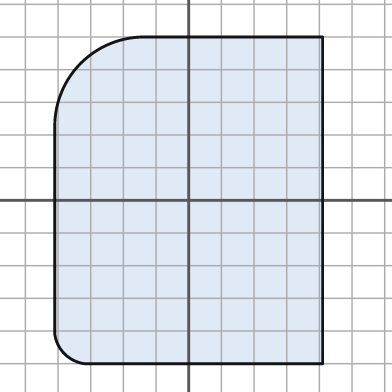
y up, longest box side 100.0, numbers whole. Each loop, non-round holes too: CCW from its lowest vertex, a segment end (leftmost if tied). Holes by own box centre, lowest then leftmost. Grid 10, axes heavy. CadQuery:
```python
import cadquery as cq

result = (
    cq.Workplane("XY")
    .moveTo(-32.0, -50.0)
    .lineTo(41.0, -50.0)
    .lineTo(41.0, 50.0)
    .lineTo(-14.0, 50.0)
    .threePointArc((-33.0, 42.0), (-41.0, 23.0))
    .lineTo(-41.0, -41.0)
    .threePointArc((-38.0, -47.0), (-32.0, -50.0))
    .close()
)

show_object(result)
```